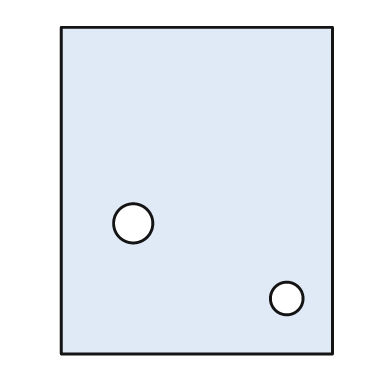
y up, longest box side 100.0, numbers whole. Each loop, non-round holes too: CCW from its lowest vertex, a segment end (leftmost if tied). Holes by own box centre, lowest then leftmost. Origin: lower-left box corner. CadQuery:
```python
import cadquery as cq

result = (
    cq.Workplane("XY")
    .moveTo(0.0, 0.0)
    .lineTo(83.0, 0.0)
    .lineTo(83.0, 100.0)
    .lineTo(0.0, 100.0)
    .close()
    .moveTo(69.0, 17.0)
    .circle(5.0)
    .moveTo(22.0, 40.0)
    .circle(6.0)
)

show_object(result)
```